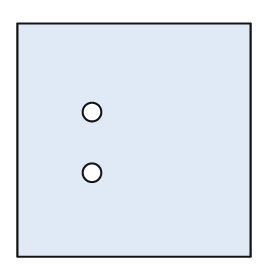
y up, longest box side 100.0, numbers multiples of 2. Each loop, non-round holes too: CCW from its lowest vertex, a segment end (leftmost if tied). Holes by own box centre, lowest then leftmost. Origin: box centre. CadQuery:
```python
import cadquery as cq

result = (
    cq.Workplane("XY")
    .moveTo(-50.0, -50.0)
    .lineTo(50.0, -50.0)
    .lineTo(50.0, 50.0)
    .lineTo(-50.0, 50.0)
    .close()
    .moveTo(-18.0, -14.0)
    .circle(4.0)
    .moveTo(-18.0, 12.0)
    .circle(4.0)
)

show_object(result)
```